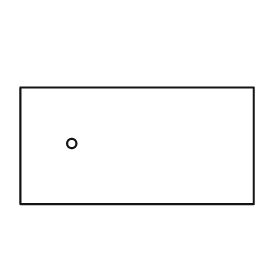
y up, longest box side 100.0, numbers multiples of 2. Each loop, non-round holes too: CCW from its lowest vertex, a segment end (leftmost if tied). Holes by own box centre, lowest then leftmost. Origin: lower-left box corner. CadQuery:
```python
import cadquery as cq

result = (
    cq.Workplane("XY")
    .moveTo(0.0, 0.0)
    .lineTo(100.0, 0.0)
    .lineTo(100.0, 50.0)
    .lineTo(0.0, 50.0)
    .close()
    .moveTo(22.0, 26.0)
    .circle(2.0)
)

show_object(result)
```